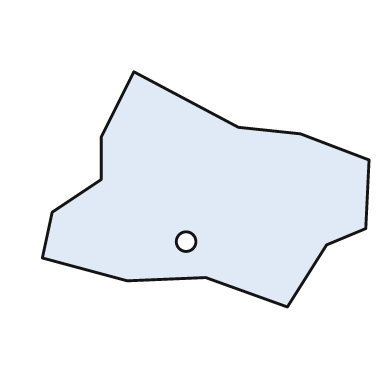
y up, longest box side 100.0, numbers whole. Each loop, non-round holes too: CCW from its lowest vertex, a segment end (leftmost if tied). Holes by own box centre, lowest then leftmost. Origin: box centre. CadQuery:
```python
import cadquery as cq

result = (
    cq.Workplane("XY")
    .moveTo(25.0, -36.0)
    .lineTo(37.0, -17.0)
    .lineTo(49.0, -12.0)
    .lineTo(50.0, 9.0)
    .lineTo(29.0, 17.0)
    .lineTo(10.0, 19.0)
    .lineTo(-22.0, 36.0)
    .lineTo(-32.0, 16.0)
    .lineTo(-32.0, 3.0)
    .lineTo(-47.0, -7.0)
    .lineTo(-50.0, -21.0)
    .lineTo(-24.0, -28.0)
    .lineTo(0.0, -27.0)
    .close()
    .moveTo(-6.0, -16.0)
    .circle(3.0)
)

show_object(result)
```